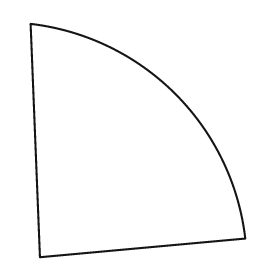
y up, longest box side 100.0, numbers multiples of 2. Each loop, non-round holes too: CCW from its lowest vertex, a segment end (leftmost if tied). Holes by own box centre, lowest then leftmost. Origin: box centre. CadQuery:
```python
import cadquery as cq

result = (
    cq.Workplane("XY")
    .moveTo(-42.0, -50.0)
    .lineTo(46.0, -42.0)
    .threePointArc((16.0, 20.0), (-46.0, 50.0))
    .close()
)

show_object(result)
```